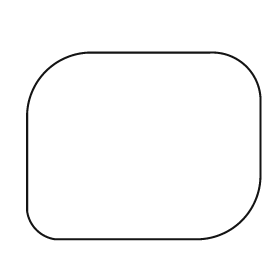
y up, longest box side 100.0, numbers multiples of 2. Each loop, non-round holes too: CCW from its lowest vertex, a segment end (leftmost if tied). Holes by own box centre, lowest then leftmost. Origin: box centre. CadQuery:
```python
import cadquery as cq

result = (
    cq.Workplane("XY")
    .moveTo(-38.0, -40.0)
    .lineTo(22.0, -40.0)
    .threePointArc((42.0, -32.0), (50.0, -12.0))
    .lineTo(50.0, 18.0)
    .threePointArc((44.0, 34.0), (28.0, 40.0))
    .lineTo(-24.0, 40.0)
    .threePointArc((-42.0, 32.0), (-50.0, 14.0))
    .lineTo(-50.0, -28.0)
    .threePointArc((-46.0, -36.0), (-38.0, -40.0))
    .close()
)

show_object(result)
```